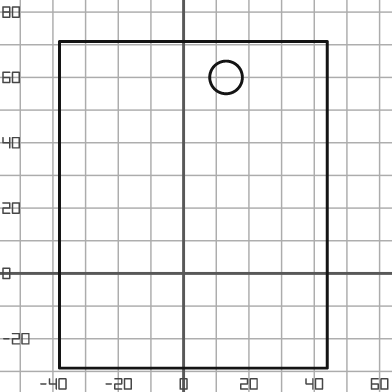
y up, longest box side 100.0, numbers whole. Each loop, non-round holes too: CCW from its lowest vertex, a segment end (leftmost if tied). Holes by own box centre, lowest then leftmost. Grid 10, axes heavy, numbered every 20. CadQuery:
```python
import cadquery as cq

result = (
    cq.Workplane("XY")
    .moveTo(-38.0, -29.0)
    .lineTo(44.0, -29.0)
    .lineTo(44.0, 71.0)
    .lineTo(-38.0, 71.0)
    .close()
    .moveTo(13.0, 60.0)
    .circle(5.0)
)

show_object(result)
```